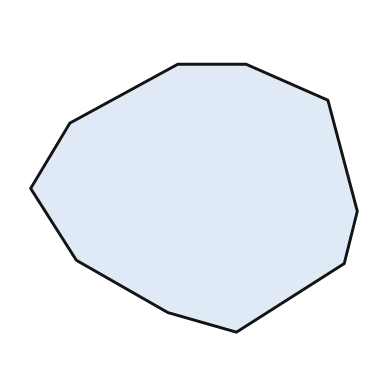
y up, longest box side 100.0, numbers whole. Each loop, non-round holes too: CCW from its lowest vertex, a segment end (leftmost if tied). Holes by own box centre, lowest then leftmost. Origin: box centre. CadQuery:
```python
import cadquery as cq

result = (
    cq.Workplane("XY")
    .moveTo(13.0, -41.0)
    .lineTo(46.0, -20.0)
    .lineTo(50.0, -4.0)
    .lineTo(41.0, 30.0)
    .lineTo(16.0, 41.0)
    .lineTo(-5.0, 41.0)
    .lineTo(-38.0, 23.0)
    .lineTo(-50.0, 3.0)
    .lineTo(-36.0, -19.0)
    .lineTo(-8.0, -35.0)
    .close()
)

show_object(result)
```